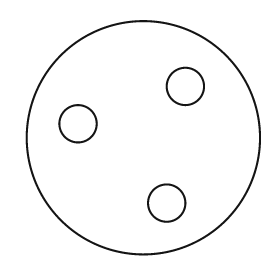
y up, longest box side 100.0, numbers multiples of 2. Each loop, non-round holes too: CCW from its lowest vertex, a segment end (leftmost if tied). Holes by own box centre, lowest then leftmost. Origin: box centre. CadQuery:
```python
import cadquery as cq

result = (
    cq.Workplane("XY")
    .moveTo(0.0, 0.0)
    .circle(50.0)
    .moveTo(10.0, -28.0)
    .circle(8.0)
    .moveTo(-28.0, 6.0)
    .circle(8.0)
    .moveTo(18.0, 22.0)
    .circle(8.0)
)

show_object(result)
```